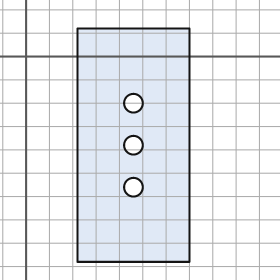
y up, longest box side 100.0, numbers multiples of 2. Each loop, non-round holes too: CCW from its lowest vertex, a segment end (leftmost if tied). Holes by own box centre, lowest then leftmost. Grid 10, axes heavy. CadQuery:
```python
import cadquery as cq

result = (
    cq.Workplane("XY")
    .moveTo(22.0, -88.0)
    .lineTo(70.0, -88.0)
    .lineTo(70.0, 12.0)
    .lineTo(22.0, 12.0)
    .close()
    .moveTo(46.0, -56.0)
    .circle(4.0)
    .moveTo(46.0, -38.0)
    .circle(4.0)
    .moveTo(46.0, -20.0)
    .circle(4.0)
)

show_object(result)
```